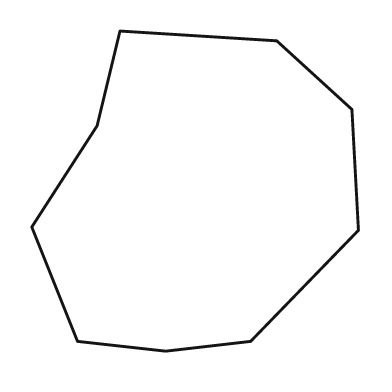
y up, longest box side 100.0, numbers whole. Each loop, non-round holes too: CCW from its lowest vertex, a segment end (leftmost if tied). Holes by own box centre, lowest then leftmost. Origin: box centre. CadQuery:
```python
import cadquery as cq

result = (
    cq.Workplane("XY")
    .moveTo(-9.0, -49.0)
    .lineTo(17.0, -46.0)
    .lineTo(50.0, -12.0)
    .lineTo(48.0, 25.0)
    .lineTo(25.0, 46.0)
    .lineTo(-23.0, 49.0)
    .lineTo(-30.0, 20.0)
    .lineTo(-50.0, -11.0)
    .lineTo(-36.0, -46.0)
    .close()
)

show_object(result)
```